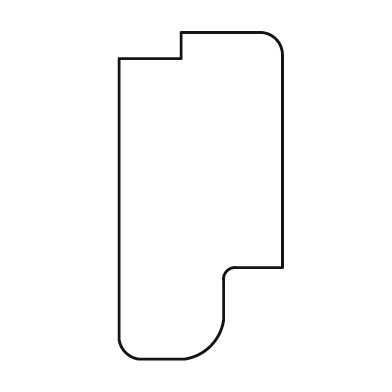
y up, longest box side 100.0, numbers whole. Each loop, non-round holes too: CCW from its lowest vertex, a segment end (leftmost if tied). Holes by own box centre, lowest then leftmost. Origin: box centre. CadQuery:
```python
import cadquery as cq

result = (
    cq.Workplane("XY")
    .moveTo(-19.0, -50.0)
    .lineTo(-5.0, -50.0)
    .threePointArc((3.0, -46.0), (7.0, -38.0))
    .lineTo(7.0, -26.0)
    .threePointArc((8.0, -23.0), (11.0, -22.0))
    .lineTo(25.0, -22.0)
    .lineTo(25.0, 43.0)
    .threePointArc((23.0, 48.0), (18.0, 50.0))
    .lineTo(-6.0, 50.0)
    .lineTo(-6.0, 42.0)
    .lineTo(-25.0, 42.0)
    .lineTo(-25.0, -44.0)
    .threePointArc((-23.0, -48.0), (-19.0, -50.0))
    .close()
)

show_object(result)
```